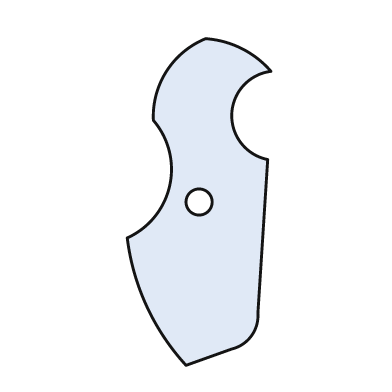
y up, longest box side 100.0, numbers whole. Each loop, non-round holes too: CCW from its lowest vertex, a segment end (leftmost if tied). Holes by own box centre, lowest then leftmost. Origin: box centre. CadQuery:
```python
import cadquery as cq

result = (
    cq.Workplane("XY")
    .moveTo(-4.0, -50.0)
    .lineTo(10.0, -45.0)
    .threePointArc((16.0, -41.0), (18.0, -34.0))
    .lineTo(21.0, 13.0)
    .threePointArc((10.0, 27.0), (22.0, 40.0))
    .threePointArc((13.0, 47.0), (2.0, 50.0))
    .threePointArc((-10.0, 40.0), (-14.0, 25.0))
    .threePointArc((-9.0, 5.0), (-22.0, -11.0))
    .threePointArc((-16.0, -32.0), (-4.0, -50.0))
    .close()
    .moveTo(0.0, 0.0)
    .circle(4.0)
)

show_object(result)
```